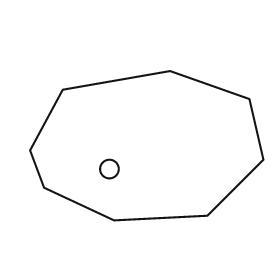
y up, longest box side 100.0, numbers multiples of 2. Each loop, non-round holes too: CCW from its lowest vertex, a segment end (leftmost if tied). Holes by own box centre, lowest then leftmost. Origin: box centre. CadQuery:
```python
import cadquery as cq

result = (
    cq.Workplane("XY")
    .moveTo(-14.0, -32.0)
    .lineTo(26.0, -30.0)
    .lineTo(50.0, -6.0)
    .lineTo(44.0, 20.0)
    .lineTo(10.0, 32.0)
    .lineTo(-36.0, 24.0)
    .lineTo(-50.0, -2.0)
    .lineTo(-44.0, -18.0)
    .close()
    .moveTo(-16.0, -10.0)
    .circle(4.0)
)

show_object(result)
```